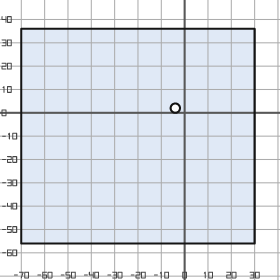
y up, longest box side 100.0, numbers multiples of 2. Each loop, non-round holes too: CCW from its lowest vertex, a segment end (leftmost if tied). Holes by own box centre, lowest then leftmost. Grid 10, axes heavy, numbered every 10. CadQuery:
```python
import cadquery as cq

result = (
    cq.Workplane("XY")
    .moveTo(-70.0, -56.0)
    .lineTo(30.0, -56.0)
    .lineTo(30.0, 36.0)
    .lineTo(-70.0, 36.0)
    .close()
    .moveTo(-4.0, 2.0)
    .circle(2.0)
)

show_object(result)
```